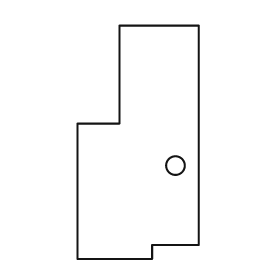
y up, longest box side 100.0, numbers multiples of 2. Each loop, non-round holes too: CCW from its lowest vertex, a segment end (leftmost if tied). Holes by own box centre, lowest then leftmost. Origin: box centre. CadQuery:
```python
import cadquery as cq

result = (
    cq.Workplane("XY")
    .moveTo(-26.0, -50.0)
    .lineTo(6.0, -50.0)
    .lineTo(6.0, -44.0)
    .lineTo(26.0, -44.0)
    .lineTo(26.0, 50.0)
    .lineTo(-8.0, 50.0)
    .lineTo(-8.0, 8.0)
    .lineTo(-26.0, 8.0)
    .close()
    .moveTo(16.0, -10.0)
    .circle(4.0)
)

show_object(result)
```